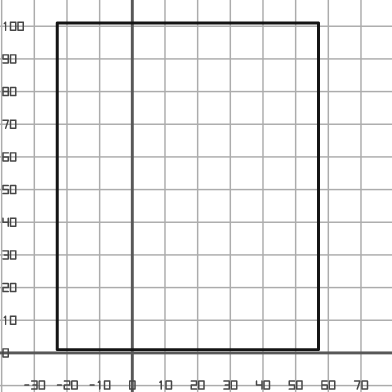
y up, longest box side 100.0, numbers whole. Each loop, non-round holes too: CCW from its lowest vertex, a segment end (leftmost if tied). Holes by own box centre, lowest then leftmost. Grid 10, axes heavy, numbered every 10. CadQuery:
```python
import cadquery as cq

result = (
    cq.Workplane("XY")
    .moveTo(-23.0, 1.0)
    .lineTo(57.0, 1.0)
    .lineTo(57.0, 101.0)
    .lineTo(-23.0, 101.0)
    .close()
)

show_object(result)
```